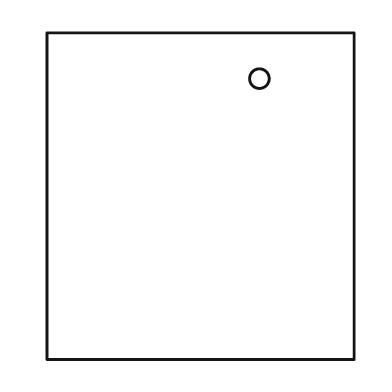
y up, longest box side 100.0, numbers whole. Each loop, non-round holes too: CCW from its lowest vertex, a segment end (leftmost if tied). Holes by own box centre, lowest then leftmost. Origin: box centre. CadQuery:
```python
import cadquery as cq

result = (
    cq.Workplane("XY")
    .moveTo(-47.0, -50.0)
    .lineTo(47.0, -50.0)
    .lineTo(47.0, 50.0)
    .lineTo(-47.0, 50.0)
    .close()
    .moveTo(18.0, 36.0)
    .circle(3.0)
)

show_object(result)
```